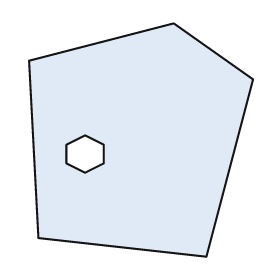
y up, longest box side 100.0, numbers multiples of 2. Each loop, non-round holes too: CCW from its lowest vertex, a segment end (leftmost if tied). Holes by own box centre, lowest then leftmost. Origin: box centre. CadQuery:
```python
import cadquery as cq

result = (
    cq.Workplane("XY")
    .moveTo(28.0, -50.0)
    .lineTo(48.0, 26.0)
    .lineTo(14.0, 50.0)
    .lineTo(-48.0, 34.0)
    .lineTo(-44.0, -42.0)
    .close()
    .moveTo(-24.0, -14.0)
    .lineTo(-16.0, -10.0)
    .lineTo(-16.0, -2.0)
    .lineTo(-24.0, 2.0)
    .lineTo(-32.0, -2.0)
    .lineTo(-32.0, -10.0)
    .close()
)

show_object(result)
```